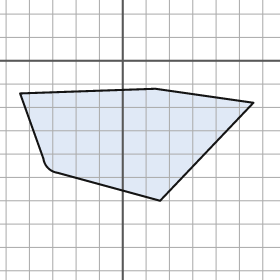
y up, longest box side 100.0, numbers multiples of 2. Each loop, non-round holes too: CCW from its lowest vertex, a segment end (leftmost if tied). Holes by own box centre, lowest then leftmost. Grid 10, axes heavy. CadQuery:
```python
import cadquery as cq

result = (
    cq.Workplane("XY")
    .moveTo(16.0, -60.0)
    .lineTo(56.0, -18.0)
    .lineTo(14.0, -12.0)
    .lineTo(-44.0, -14.0)
    .lineTo(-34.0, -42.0)
    .threePointArc((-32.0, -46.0), (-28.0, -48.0))
    .close()
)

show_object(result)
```